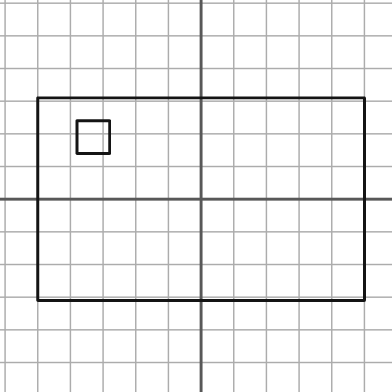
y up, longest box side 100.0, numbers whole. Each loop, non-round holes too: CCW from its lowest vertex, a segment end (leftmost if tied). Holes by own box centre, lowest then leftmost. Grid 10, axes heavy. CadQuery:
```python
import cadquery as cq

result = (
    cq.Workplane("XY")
    .moveTo(-50.0, -31.0)
    .lineTo(50.0, -31.0)
    .lineTo(50.0, 31.0)
    .lineTo(-50.0, 31.0)
    .close()
    .moveTo(-38.0, 14.0)
    .lineTo(-28.0, 14.0)
    .lineTo(-28.0, 24.0)
    .lineTo(-38.0, 24.0)
    .close()
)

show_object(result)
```